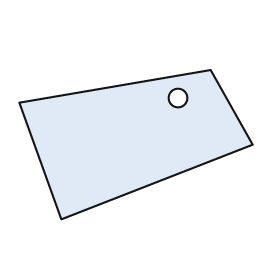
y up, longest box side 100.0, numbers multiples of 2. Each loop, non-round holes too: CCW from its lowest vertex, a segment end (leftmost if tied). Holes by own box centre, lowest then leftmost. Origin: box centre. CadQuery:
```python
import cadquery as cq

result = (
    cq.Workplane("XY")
    .moveTo(-32.0, -32.0)
    .lineTo(50.0, 0.0)
    .lineTo(32.0, 32.0)
    .lineTo(-50.0, 18.0)
    .close()
    .moveTo(18.0, 20.0)
    .circle(4.0)
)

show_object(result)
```